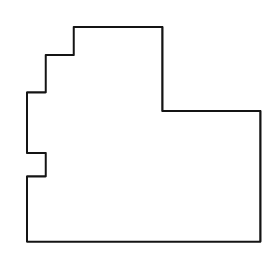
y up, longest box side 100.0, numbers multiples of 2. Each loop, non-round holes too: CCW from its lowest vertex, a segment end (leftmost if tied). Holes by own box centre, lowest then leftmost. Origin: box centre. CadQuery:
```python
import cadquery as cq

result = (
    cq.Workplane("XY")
    .moveTo(-50.0, -46.0)
    .lineTo(50.0, -46.0)
    .lineTo(50.0, 10.0)
    .lineTo(8.0, 10.0)
    .lineTo(8.0, 46.0)
    .lineTo(-30.0, 46.0)
    .lineTo(-30.0, 34.0)
    .lineTo(-42.0, 34.0)
    .lineTo(-42.0, 18.0)
    .lineTo(-50.0, 18.0)
    .lineTo(-50.0, -8.0)
    .lineTo(-42.0, -8.0)
    .lineTo(-42.0, -18.0)
    .lineTo(-50.0, -18.0)
    .close()
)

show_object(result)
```